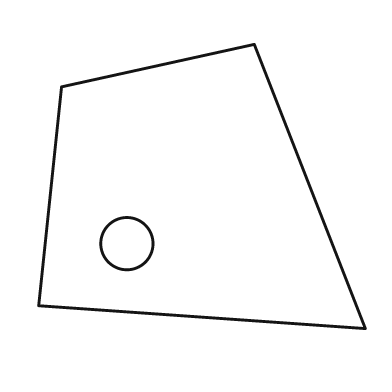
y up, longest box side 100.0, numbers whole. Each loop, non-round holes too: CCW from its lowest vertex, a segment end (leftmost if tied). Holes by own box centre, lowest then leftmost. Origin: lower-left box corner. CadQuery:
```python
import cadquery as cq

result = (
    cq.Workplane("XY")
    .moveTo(100.0, 0.0)
    .lineTo(66.0, 87.0)
    .lineTo(7.0, 74.0)
    .lineTo(0.0, 7.0)
    .close()
    .moveTo(27.0, 26.0)
    .circle(8.0)
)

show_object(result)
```